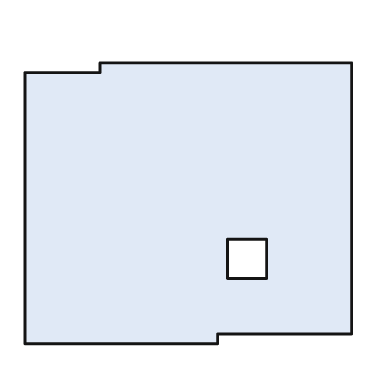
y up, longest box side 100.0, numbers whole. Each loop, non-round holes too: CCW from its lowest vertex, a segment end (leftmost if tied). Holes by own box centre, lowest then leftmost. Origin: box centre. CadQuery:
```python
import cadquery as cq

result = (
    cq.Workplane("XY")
    .moveTo(-50.0, -43.0)
    .lineTo(9.0, -43.0)
    .lineTo(9.0, -40.0)
    .lineTo(50.0, -40.0)
    .lineTo(50.0, 43.0)
    .lineTo(-27.0, 43.0)
    .lineTo(-27.0, 40.0)
    .lineTo(-50.0, 40.0)
    .close()
    .moveTo(12.0, -23.0)
    .lineTo(24.0, -23.0)
    .lineTo(24.0, -11.0)
    .lineTo(12.0, -11.0)
    .close()
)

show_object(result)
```